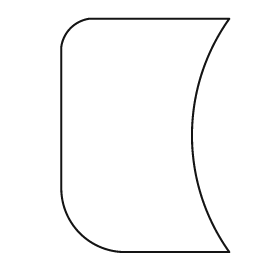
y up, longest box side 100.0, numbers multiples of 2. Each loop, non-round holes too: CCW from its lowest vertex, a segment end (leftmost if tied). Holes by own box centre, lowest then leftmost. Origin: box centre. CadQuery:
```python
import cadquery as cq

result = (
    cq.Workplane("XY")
    .moveTo(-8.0, -50.0)
    .lineTo(36.0, -50.0)
    .threePointArc((20.0, 0.0), (36.0, 50.0))
    .lineTo(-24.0, 50.0)
    .threePointArc((-32.0, 46.0), (-36.0, 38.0))
    .lineTo(-36.0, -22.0)
    .threePointArc((-28.0, -42.0), (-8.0, -50.0))
    .close()
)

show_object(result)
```